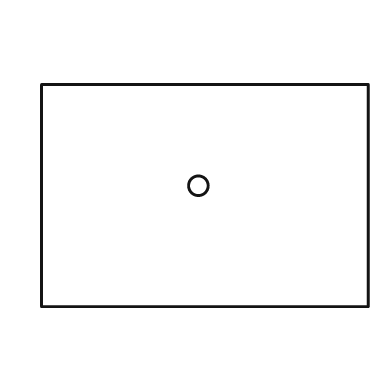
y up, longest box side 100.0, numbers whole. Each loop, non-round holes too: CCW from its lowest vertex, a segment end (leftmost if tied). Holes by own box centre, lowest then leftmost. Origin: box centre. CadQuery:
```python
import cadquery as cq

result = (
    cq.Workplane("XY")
    .moveTo(-50.0, -34.0)
    .lineTo(50.0, -34.0)
    .lineTo(50.0, 34.0)
    .lineTo(-50.0, 34.0)
    .close()
    .moveTo(-2.0, 3.0)
    .circle(3.0)
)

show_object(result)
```